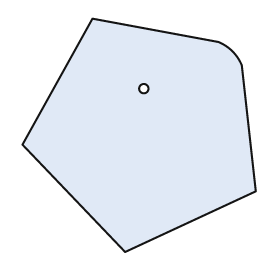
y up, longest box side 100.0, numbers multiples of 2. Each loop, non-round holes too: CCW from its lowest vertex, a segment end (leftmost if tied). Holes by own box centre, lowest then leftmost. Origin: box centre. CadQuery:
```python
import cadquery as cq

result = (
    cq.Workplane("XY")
    .moveTo(-6.0, -50.0)
    .lineTo(50.0, -24.0)
    .lineTo(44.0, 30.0)
    .threePointArc((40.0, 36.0), (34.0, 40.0))
    .lineTo(-20.0, 50.0)
    .lineTo(-50.0, -4.0)
    .close()
    .moveTo(2.0, 20.0)
    .circle(2.0)
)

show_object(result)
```